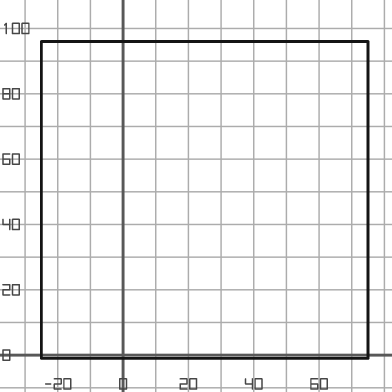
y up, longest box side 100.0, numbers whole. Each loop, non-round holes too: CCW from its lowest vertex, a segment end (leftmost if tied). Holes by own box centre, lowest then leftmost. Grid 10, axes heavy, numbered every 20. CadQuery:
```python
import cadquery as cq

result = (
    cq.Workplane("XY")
    .moveTo(-25.0, -1.0)
    .lineTo(75.0, -1.0)
    .lineTo(75.0, 96.0)
    .lineTo(-25.0, 96.0)
    .close()
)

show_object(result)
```